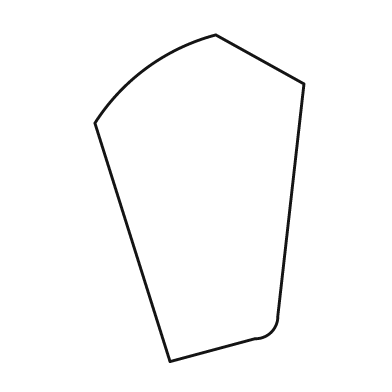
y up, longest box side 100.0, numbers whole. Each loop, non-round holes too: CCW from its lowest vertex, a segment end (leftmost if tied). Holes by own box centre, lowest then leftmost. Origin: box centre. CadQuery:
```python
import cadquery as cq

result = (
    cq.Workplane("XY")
    .moveTo(-9.0, -50.0)
    .lineTo(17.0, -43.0)
    .threePointArc((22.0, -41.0), (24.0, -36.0))
    .lineTo(32.0, 35.0)
    .lineTo(5.0, 50.0)
    .threePointArc((-16.0, 40.0), (-32.0, 23.0))
    .close()
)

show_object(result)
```